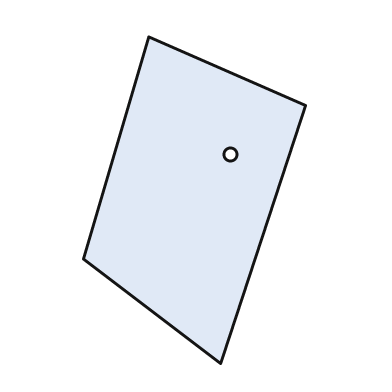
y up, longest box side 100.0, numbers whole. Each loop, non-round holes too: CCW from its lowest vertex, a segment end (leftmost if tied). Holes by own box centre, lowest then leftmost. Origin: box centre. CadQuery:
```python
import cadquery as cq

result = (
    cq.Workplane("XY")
    .moveTo(8.0, -50.0)
    .lineTo(34.0, 29.0)
    .lineTo(-14.0, 50.0)
    .lineTo(-34.0, -18.0)
    .close()
    .moveTo(11.0, 14.0)
    .circle(2.0)
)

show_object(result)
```